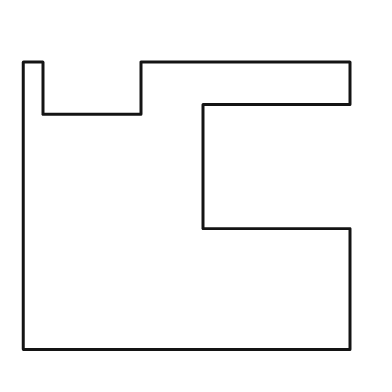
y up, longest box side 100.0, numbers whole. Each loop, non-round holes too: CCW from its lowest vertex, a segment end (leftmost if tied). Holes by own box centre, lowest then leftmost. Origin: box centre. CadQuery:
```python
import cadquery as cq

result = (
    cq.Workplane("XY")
    .moveTo(-50.0, -44.0)
    .lineTo(50.0, -44.0)
    .lineTo(50.0, -7.0)
    .lineTo(5.0, -7.0)
    .lineTo(5.0, 31.0)
    .lineTo(50.0, 31.0)
    .lineTo(50.0, 44.0)
    .lineTo(-14.0, 44.0)
    .lineTo(-14.0, 28.0)
    .lineTo(-44.0, 28.0)
    .lineTo(-44.0, 44.0)
    .lineTo(-50.0, 44.0)
    .close()
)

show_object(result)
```